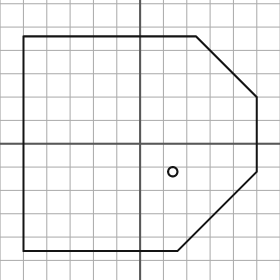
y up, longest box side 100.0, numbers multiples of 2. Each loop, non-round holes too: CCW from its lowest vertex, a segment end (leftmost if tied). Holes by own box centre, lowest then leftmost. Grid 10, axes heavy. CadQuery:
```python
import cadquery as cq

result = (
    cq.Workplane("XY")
    .moveTo(-50.0, -46.0)
    .lineTo(16.0, -46.0)
    .lineTo(50.0, -12.0)
    .lineTo(50.0, 20.0)
    .lineTo(24.0, 46.0)
    .lineTo(-50.0, 46.0)
    .close()
    .moveTo(14.0, -12.0)
    .circle(2.0)
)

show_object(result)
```